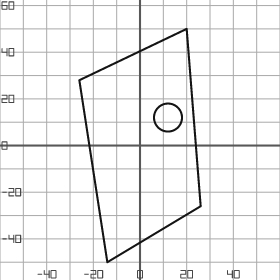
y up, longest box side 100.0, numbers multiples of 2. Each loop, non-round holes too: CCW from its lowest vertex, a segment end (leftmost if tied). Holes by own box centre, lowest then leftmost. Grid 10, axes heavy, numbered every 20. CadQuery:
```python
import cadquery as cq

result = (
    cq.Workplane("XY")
    .moveTo(-14.0, -50.0)
    .lineTo(26.0, -26.0)
    .lineTo(20.0, 50.0)
    .lineTo(-26.0, 28.0)
    .close()
    .moveTo(12.0, 12.0)
    .circle(6.0)
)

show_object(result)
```